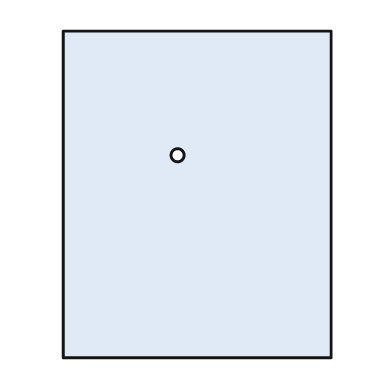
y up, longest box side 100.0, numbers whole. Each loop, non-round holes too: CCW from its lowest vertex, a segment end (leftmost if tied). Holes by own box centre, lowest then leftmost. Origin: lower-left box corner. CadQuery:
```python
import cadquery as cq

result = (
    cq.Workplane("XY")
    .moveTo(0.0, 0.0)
    .lineTo(82.0, 0.0)
    .lineTo(82.0, 100.0)
    .lineTo(0.0, 100.0)
    .close()
    .moveTo(35.0, 62.0)
    .circle(2.0)
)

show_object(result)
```